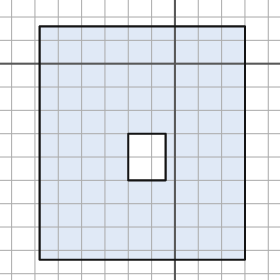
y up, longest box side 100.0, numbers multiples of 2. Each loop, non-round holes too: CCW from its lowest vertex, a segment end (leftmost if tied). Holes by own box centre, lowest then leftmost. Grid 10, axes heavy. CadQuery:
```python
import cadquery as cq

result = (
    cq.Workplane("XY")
    .moveTo(-58.0, -84.0)
    .lineTo(30.0, -84.0)
    .lineTo(30.0, 16.0)
    .lineTo(-58.0, 16.0)
    .close()
    .moveTo(-20.0, -50.0)
    .lineTo(-4.0, -50.0)
    .lineTo(-4.0, -30.0)
    .lineTo(-20.0, -30.0)
    .close()
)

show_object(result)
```